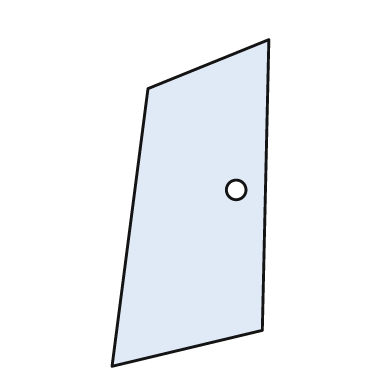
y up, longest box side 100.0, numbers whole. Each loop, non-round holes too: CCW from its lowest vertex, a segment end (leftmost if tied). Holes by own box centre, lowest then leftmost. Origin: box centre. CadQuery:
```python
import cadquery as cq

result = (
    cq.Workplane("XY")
    .moveTo(-24.0, -50.0)
    .lineTo(22.0, -39.0)
    .lineTo(24.0, 50.0)
    .lineTo(-13.0, 35.0)
    .close()
    .moveTo(14.0, 4.0)
    .circle(3.0)
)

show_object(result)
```